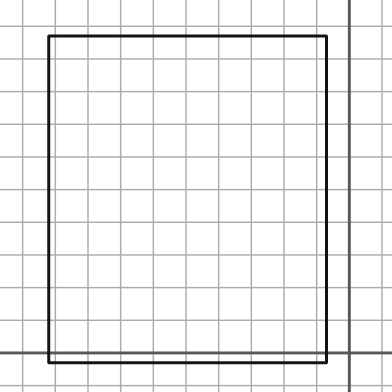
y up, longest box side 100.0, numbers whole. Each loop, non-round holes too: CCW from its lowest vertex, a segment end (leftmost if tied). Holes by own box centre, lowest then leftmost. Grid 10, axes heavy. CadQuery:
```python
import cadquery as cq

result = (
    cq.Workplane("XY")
    .moveTo(-92.0, -3.0)
    .lineTo(-7.0, -3.0)
    .lineTo(-7.0, 97.0)
    .lineTo(-92.0, 97.0)
    .close()
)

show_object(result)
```